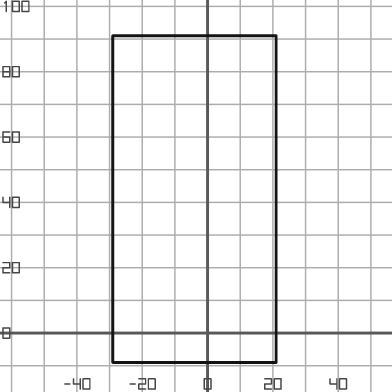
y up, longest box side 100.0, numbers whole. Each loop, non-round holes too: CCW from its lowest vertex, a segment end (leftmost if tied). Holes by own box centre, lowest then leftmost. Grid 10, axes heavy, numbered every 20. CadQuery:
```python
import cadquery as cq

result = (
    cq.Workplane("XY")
    .moveTo(-29.0, -9.0)
    .lineTo(21.0, -9.0)
    .lineTo(21.0, 91.0)
    .lineTo(-29.0, 91.0)
    .close()
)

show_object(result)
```